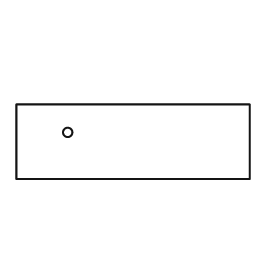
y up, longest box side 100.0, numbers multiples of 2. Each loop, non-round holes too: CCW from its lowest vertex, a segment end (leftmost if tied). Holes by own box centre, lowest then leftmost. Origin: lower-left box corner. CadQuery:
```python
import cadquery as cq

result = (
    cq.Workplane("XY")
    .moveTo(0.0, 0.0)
    .lineTo(100.0, 0.0)
    .lineTo(100.0, 32.0)
    .lineTo(0.0, 32.0)
    .close()
    .moveTo(22.0, 20.0)
    .circle(2.0)
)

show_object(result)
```